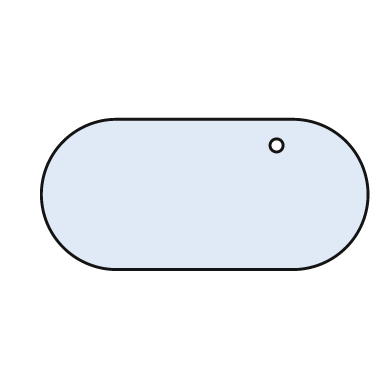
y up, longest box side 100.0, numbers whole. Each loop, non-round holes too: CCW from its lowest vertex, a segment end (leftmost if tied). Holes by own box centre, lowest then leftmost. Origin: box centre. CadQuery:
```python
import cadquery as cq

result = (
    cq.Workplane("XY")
    .moveTo(-27.0, -23.0)
    .lineTo(27.0, -23.0)
    .threePointArc((50.0, 0.0), (27.0, 23.0))
    .lineTo(-27.0, 23.0)
    .threePointArc((-50.0, 0.0), (-27.0, -23.0))
    .close()
    .moveTo(22.0, 15.0)
    .circle(2.0)
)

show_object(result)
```